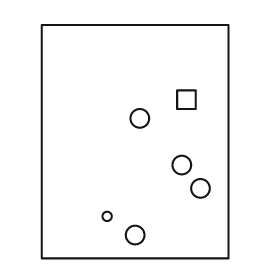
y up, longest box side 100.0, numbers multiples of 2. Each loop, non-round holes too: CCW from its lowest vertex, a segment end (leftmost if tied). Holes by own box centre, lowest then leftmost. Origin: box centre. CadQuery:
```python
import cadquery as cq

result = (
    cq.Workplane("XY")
    .moveTo(-40.0, -50.0)
    .lineTo(40.0, -50.0)
    .lineTo(40.0, 50.0)
    .lineTo(-40.0, 50.0)
    .close()
    .moveTo(0.0, -40.0)
    .circle(4.0)
    .moveTo(-12.0, -32.0)
    .circle(2.0)
    .moveTo(28.0, -20.0)
    .circle(4.0)
    .moveTo(20.0, -10.0)
    .circle(4.0)
    .moveTo(2.0, 10.0)
    .circle(4.0)
    .moveTo(18.0, 14.0)
    .lineTo(26.0, 14.0)
    .lineTo(26.0, 22.0)
    .lineTo(18.0, 22.0)
    .close()
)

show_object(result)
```